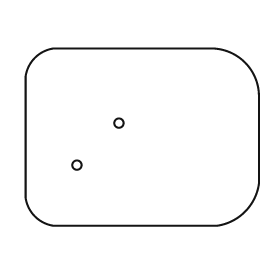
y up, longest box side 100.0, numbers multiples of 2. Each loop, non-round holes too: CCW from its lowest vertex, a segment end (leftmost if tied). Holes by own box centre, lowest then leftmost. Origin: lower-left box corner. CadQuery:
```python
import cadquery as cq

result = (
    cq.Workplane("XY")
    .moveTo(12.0, 0.0)
    .lineTo(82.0, 0.0)
    .threePointArc((94.0, 6.0), (100.0, 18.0))
    .lineTo(100.0, 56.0)
    .threePointArc((94.0, 70.0), (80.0, 76.0))
    .lineTo(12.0, 76.0)
    .threePointArc((4.0, 72.0), (0.0, 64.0))
    .lineTo(0.0, 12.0)
    .threePointArc((4.0, 4.0), (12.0, 0.0))
    .close()
    .moveTo(22.0, 26.0)
    .circle(2.0)
    .moveTo(40.0, 44.0)
    .circle(2.0)
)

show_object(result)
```